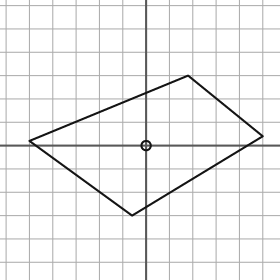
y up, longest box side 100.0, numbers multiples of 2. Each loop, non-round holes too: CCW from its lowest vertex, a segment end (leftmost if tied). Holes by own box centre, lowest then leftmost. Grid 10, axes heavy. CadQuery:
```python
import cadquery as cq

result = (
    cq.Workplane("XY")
    .moveTo(-6.0, -30.0)
    .lineTo(50.0, 4.0)
    .lineTo(18.0, 30.0)
    .lineTo(-50.0, 2.0)
    .close()
    .moveTo(0.0, 0.0)
    .circle(2.0)
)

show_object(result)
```